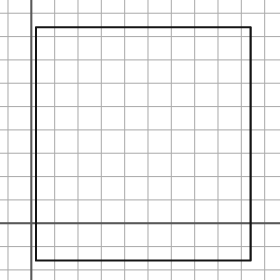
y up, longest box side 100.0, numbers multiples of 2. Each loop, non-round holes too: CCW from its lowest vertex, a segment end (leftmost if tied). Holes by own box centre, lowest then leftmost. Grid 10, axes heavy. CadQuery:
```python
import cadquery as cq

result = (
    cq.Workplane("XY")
    .moveTo(2.0, -16.0)
    .lineTo(94.0, -16.0)
    .lineTo(94.0, 84.0)
    .lineTo(2.0, 84.0)
    .close()
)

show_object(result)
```